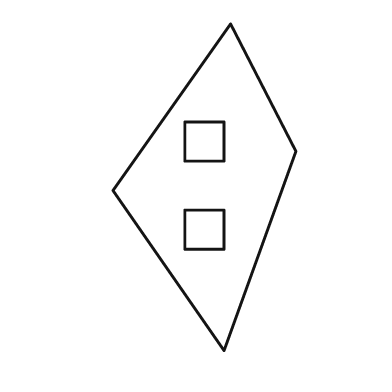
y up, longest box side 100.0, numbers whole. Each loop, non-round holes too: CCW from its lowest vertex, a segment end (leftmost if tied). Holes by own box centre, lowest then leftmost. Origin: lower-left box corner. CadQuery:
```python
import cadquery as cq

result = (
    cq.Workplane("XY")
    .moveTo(34.0, 0.0)
    .lineTo(56.0, 61.0)
    .lineTo(36.0, 100.0)
    .lineTo(0.0, 49.0)
    .close()
    .moveTo(22.0, 31.0)
    .lineTo(34.0, 31.0)
    .lineTo(34.0, 43.0)
    .lineTo(22.0, 43.0)
    .close()
    .moveTo(22.0, 58.0)
    .lineTo(34.0, 58.0)
    .lineTo(34.0, 70.0)
    .lineTo(22.0, 70.0)
    .close()
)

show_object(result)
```